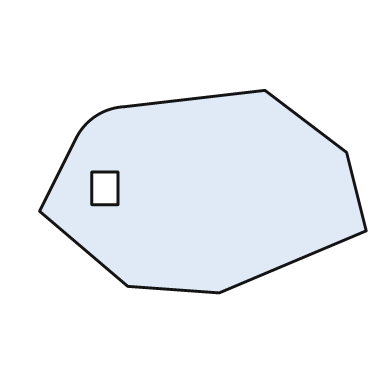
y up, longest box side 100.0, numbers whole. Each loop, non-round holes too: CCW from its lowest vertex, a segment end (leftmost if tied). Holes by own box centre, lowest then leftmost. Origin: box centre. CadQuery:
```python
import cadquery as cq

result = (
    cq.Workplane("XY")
    .moveTo(5.0, -31.0)
    .lineTo(50.0, -12.0)
    .lineTo(44.0, 12.0)
    .lineTo(19.0, 31.0)
    .lineTo(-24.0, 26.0)
    .threePointArc((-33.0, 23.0), (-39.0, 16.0))
    .lineTo(-50.0, -6.0)
    .lineTo(-23.0, -29.0)
    .close()
    .moveTo(-34.0, -4.0)
    .lineTo(-26.0, -4.0)
    .lineTo(-26.0, 6.0)
    .lineTo(-34.0, 6.0)
    .close()
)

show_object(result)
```